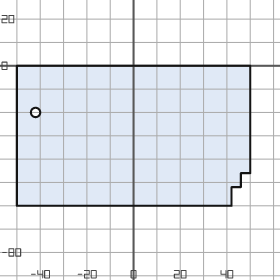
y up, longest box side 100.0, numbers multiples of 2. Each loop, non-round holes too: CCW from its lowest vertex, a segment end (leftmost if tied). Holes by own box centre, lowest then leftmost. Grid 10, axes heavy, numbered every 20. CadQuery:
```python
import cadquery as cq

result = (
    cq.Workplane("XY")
    .moveTo(-50.0, -60.0)
    .lineTo(42.0, -60.0)
    .lineTo(42.0, -52.0)
    .lineTo(46.0, -52.0)
    .lineTo(46.0, -46.0)
    .lineTo(50.0, -46.0)
    .lineTo(50.0, 0.0)
    .lineTo(-50.0, 0.0)
    .close()
    .moveTo(-42.0, -20.0)
    .circle(2.0)
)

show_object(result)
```